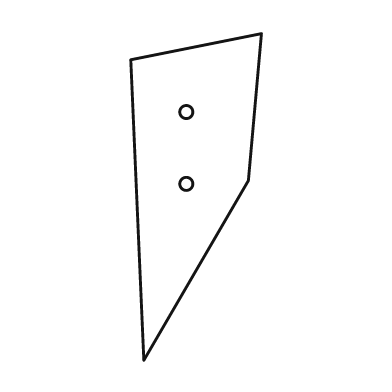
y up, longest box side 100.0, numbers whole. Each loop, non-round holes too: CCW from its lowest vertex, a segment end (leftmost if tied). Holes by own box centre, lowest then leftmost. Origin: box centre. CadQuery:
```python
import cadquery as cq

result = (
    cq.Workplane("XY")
    .moveTo(-16.0, -50.0)
    .lineTo(16.0, 5.0)
    .lineTo(20.0, 50.0)
    .lineTo(-20.0, 42.0)
    .close()
    .moveTo(-3.0, 4.0)
    .circle(2.0)
    .moveTo(-3.0, 26.0)
    .circle(2.0)
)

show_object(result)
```